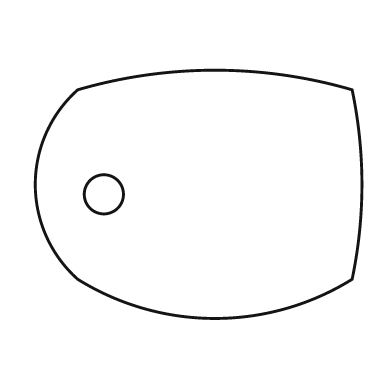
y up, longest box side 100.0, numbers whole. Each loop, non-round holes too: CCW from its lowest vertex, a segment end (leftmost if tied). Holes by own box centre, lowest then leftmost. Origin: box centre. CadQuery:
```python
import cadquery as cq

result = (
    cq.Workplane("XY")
    .moveTo(-37.0, -26.0)
    .threePointArc((5.0, -38.0), (47.0, -26.0))
    .threePointArc((50.0, 3.0), (47.0, 32.0))
    .threePointArc((5.0, 38.0), (-37.0, 32.0))
    .threePointArc((-50.0, 3.0), (-37.0, -26.0))
    .close()
    .moveTo(-29.0, 0.0)
    .circle(6.0)
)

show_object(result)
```